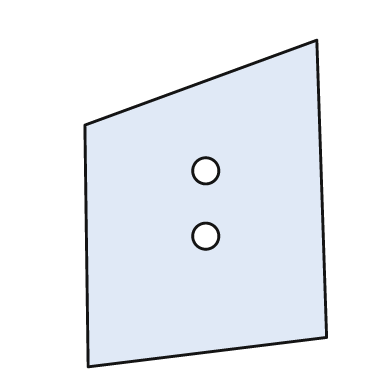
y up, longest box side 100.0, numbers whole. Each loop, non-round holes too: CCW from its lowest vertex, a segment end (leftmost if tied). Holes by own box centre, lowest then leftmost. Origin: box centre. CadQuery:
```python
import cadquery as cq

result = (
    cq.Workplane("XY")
    .moveTo(-36.0, -50.0)
    .lineTo(37.0, -41.0)
    .lineTo(34.0, 50.0)
    .lineTo(-37.0, 24.0)
    .close()
    .moveTo(0.0, -10.0)
    .circle(4.0)
    .moveTo(0.0, 10.0)
    .circle(4.0)
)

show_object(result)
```